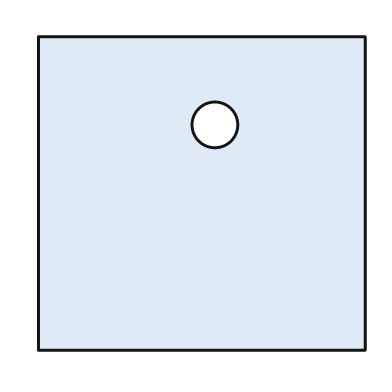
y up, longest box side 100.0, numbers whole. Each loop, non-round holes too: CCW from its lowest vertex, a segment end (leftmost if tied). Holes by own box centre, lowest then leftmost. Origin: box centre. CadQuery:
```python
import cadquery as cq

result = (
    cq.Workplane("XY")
    .moveTo(-50.0, -48.0)
    .lineTo(50.0, -48.0)
    .lineTo(50.0, 48.0)
    .lineTo(-50.0, 48.0)
    .close()
    .moveTo(4.0, 21.0)
    .circle(7.0)
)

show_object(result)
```